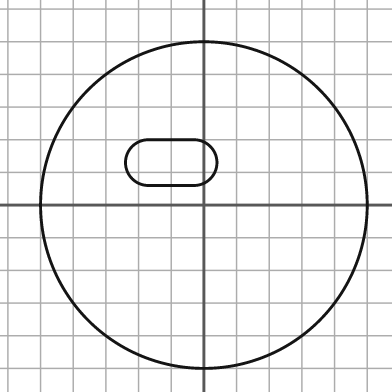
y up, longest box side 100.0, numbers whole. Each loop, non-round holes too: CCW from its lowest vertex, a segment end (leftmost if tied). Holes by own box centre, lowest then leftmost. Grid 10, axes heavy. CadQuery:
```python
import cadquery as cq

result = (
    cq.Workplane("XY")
    .moveTo(0.0, 0.0)
    .circle(50.0)
    .moveTo(-17.0, 6.0)
    .lineTo(-3.0, 6.0)
    .threePointArc((4.0, 13.0), (-3.0, 20.0))
    .lineTo(-17.0, 20.0)
    .threePointArc((-24.0, 13.0), (-17.0, 6.0))
    .close()
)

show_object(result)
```